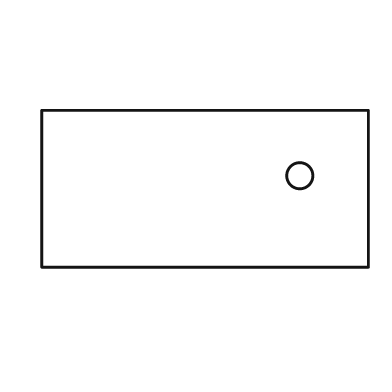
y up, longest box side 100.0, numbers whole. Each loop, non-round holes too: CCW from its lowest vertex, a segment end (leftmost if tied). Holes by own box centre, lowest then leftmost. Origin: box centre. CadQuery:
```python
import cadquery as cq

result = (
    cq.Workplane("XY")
    .moveTo(-50.0, -24.0)
    .lineTo(50.0, -24.0)
    .lineTo(50.0, 24.0)
    .lineTo(-50.0, 24.0)
    .close()
    .moveTo(29.0, 4.0)
    .circle(4.0)
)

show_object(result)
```